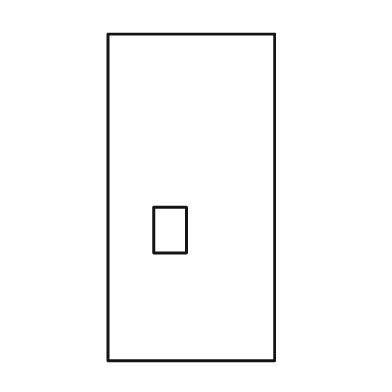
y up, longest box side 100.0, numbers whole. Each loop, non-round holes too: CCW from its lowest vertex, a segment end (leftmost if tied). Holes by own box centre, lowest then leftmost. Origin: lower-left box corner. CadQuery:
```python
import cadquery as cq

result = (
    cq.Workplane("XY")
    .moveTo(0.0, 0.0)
    .lineTo(51.0, 0.0)
    .lineTo(51.0, 100.0)
    .lineTo(0.0, 100.0)
    .close()
    .moveTo(14.0, 33.0)
    .lineTo(24.0, 33.0)
    .lineTo(24.0, 47.0)
    .lineTo(14.0, 47.0)
    .close()
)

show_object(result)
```